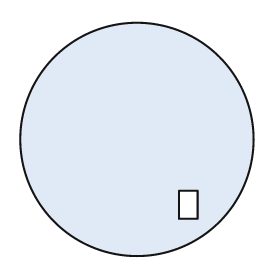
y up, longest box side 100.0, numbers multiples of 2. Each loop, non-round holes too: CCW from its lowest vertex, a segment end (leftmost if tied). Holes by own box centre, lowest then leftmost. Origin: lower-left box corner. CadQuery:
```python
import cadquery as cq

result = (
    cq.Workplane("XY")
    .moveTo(50.0, 50.0)
    .circle(50.0)
    .moveTo(68.0, 16.0)
    .lineTo(76.0, 16.0)
    .lineTo(76.0, 28.0)
    .lineTo(68.0, 28.0)
    .close()
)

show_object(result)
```